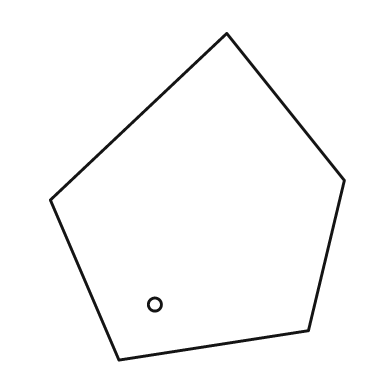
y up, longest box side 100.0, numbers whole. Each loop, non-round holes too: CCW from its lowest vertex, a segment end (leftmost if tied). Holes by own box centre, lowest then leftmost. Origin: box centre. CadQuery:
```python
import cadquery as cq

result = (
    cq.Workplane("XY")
    .moveTo(-24.0, -50.0)
    .lineTo(34.0, -41.0)
    .lineTo(45.0, 5.0)
    .lineTo(9.0, 50.0)
    .lineTo(-45.0, -1.0)
    .close()
    .moveTo(-13.0, -33.0)
    .circle(2.0)
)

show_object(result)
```